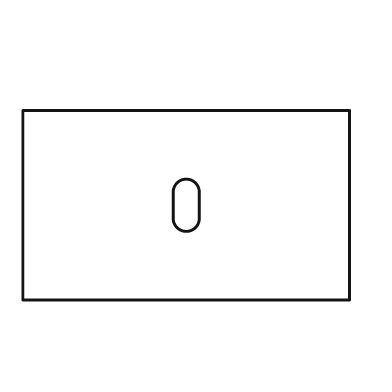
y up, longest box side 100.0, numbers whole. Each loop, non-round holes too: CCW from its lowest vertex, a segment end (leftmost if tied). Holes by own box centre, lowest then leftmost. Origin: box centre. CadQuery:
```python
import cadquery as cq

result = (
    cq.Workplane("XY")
    .moveTo(-50.0, -29.0)
    .lineTo(50.0, -29.0)
    .lineTo(50.0, 29.0)
    .lineTo(-50.0, 29.0)
    .close()
    .moveTo(-4.0, -4.0)
    .threePointArc((0.0, -8.0), (4.0, -4.0))
    .lineTo(4.0, 4.0)
    .threePointArc((0.0, 8.0), (-4.0, 4.0))
    .close()
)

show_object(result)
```